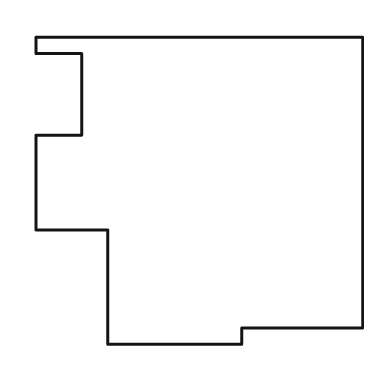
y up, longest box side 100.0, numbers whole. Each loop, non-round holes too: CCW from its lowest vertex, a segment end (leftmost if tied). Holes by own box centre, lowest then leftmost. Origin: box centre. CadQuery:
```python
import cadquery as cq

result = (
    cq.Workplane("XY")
    .moveTo(-28.0, -47.0)
    .lineTo(13.0, -47.0)
    .lineTo(13.0, -42.0)
    .lineTo(50.0, -42.0)
    .lineTo(50.0, 47.0)
    .lineTo(-50.0, 47.0)
    .lineTo(-50.0, 42.0)
    .lineTo(-36.0, 42.0)
    .lineTo(-36.0, 17.0)
    .lineTo(-50.0, 17.0)
    .lineTo(-50.0, -12.0)
    .lineTo(-28.0, -12.0)
    .close()
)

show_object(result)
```